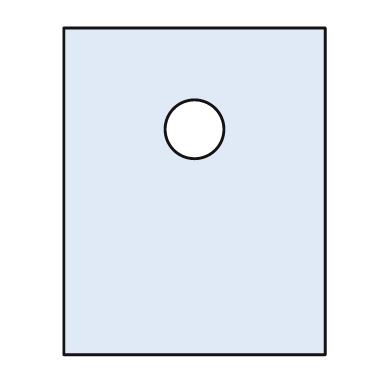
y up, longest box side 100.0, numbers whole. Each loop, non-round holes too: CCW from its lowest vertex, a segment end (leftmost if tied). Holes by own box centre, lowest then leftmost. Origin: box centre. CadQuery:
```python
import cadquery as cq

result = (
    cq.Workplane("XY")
    .moveTo(-40.0, -50.0)
    .lineTo(40.0, -50.0)
    .lineTo(40.0, 50.0)
    .lineTo(-40.0, 50.0)
    .close()
    .moveTo(0.0, 19.0)
    .circle(9.0)
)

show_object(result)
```